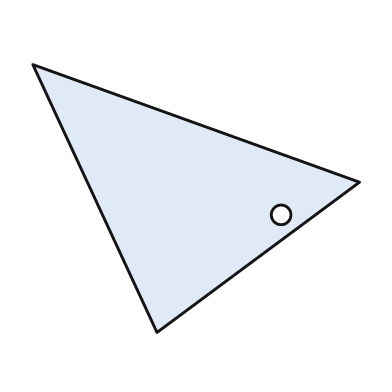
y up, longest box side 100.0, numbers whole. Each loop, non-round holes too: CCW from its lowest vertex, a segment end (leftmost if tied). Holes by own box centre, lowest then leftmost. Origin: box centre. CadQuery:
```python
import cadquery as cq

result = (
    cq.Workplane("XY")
    .moveTo(-12.0, -41.0)
    .lineTo(50.0, 5.0)
    .lineTo(-50.0, 41.0)
    .close()
    .moveTo(26.0, -5.0)
    .circle(3.0)
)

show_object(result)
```